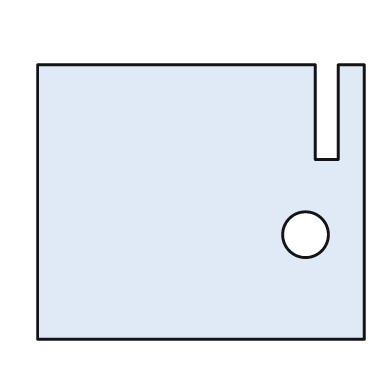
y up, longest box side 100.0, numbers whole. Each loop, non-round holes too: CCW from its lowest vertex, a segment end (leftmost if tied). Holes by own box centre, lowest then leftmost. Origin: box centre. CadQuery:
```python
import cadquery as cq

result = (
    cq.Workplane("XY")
    .moveTo(-50.0, -42.0)
    .lineTo(50.0, -42.0)
    .lineTo(50.0, 42.0)
    .lineTo(42.0, 42.0)
    .lineTo(42.0, 13.0)
    .lineTo(35.0, 13.0)
    .lineTo(35.0, 42.0)
    .lineTo(-50.0, 42.0)
    .close()
    .moveTo(32.0, -10.0)
    .circle(7.0)
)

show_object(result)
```